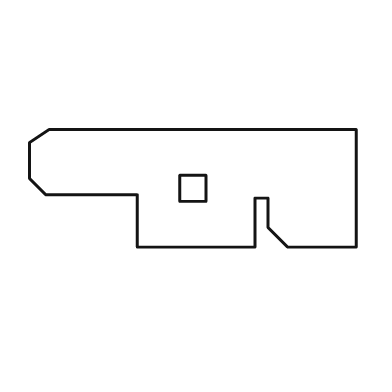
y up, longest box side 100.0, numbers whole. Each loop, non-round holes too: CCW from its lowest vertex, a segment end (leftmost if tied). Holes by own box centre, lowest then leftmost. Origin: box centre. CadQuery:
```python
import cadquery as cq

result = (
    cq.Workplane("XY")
    .moveTo(-17.0, -18.0)
    .lineTo(19.0, -18.0)
    .lineTo(19.0, -3.0)
    .lineTo(23.0, -3.0)
    .lineTo(23.0, -12.0)
    .lineTo(29.0, -18.0)
    .lineTo(50.0, -18.0)
    .lineTo(50.0, 18.0)
    .lineTo(-44.0, 18.0)
    .lineTo(-50.0, 14.0)
    .lineTo(-50.0, 3.0)
    .lineTo(-45.0, -2.0)
    .lineTo(-17.0, -2.0)
    .close()
    .moveTo(-4.0, -4.0)
    .lineTo(4.0, -4.0)
    .lineTo(4.0, 4.0)
    .lineTo(-4.0, 4.0)
    .close()
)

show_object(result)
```